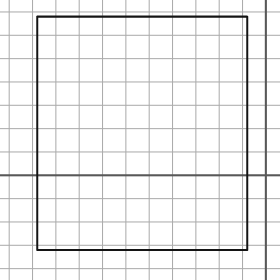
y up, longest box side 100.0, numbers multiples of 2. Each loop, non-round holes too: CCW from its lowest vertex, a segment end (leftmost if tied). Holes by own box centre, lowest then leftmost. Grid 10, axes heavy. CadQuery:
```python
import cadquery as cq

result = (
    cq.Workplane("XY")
    .moveTo(-98.0, -32.0)
    .lineTo(-8.0, -32.0)
    .lineTo(-8.0, 68.0)
    .lineTo(-98.0, 68.0)
    .close()
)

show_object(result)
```